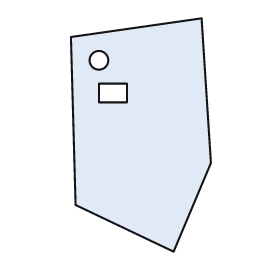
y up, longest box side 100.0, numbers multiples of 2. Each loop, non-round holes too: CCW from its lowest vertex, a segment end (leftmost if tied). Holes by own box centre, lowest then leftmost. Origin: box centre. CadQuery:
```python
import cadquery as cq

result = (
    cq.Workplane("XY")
    .moveTo(14.0, -50.0)
    .lineTo(30.0, -12.0)
    .lineTo(26.0, 50.0)
    .lineTo(-30.0, 42.0)
    .lineTo(-28.0, -30.0)
    .close()
    .moveTo(-18.0, 14.0)
    .lineTo(-6.0, 14.0)
    .lineTo(-6.0, 22.0)
    .lineTo(-18.0, 22.0)
    .close()
    .moveTo(-18.0, 32.0)
    .circle(4.0)
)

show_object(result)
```